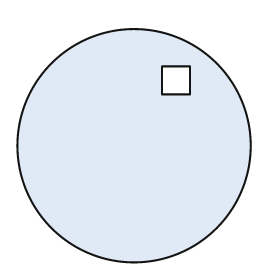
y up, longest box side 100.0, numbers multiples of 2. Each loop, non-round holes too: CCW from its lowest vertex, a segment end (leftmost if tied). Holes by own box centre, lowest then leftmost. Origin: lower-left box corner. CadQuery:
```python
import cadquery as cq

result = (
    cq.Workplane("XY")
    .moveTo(50.0, 50.0)
    .circle(50.0)
    .moveTo(62.0, 72.0)
    .lineTo(74.0, 72.0)
    .lineTo(74.0, 84.0)
    .lineTo(62.0, 84.0)
    .close()
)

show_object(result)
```